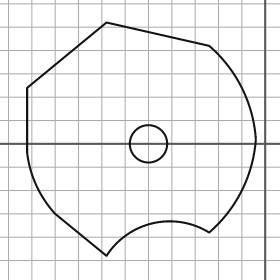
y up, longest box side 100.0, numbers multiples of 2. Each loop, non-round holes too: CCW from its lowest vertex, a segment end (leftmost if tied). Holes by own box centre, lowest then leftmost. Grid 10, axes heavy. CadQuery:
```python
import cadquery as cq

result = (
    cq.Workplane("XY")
    .moveTo(-68.0, -48.0)
    .threePointArc((-48.0, -34.0), (-24.0, -38.0))
    .threePointArc((-10.0, -20.0), (-4.0, 2.0))
    .threePointArc((-10.0, 24.0), (-24.0, 42.0))
    .lineTo(-68.0, 52.0)
    .lineTo(-102.0, 24.0)
    .lineTo(-102.0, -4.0)
    .threePointArc((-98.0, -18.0), (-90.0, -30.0))
    .close()
    .moveTo(-50.0, 0.0)
    .circle(8.0)
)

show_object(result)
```